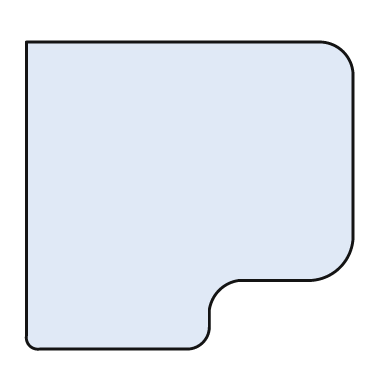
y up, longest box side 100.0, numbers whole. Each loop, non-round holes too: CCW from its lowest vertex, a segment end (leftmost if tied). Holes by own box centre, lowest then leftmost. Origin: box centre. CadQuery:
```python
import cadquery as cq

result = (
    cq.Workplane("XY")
    .moveTo(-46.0, -47.0)
    .lineTo(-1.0, -47.0)
    .threePointArc((4.0, -45.0), (6.0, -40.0))
    .lineTo(6.0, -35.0)
    .threePointArc((9.0, -29.0), (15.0, -26.0))
    .lineTo(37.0, -26.0)
    .threePointArc((46.0, -22.0), (50.0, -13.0))
    .lineTo(50.0, 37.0)
    .threePointArc((47.0, 44.0), (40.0, 47.0))
    .lineTo(-50.0, 47.0)
    .lineTo(-50.0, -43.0)
    .threePointArc((-49.0, -46.0), (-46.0, -47.0))
    .close()
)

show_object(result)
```